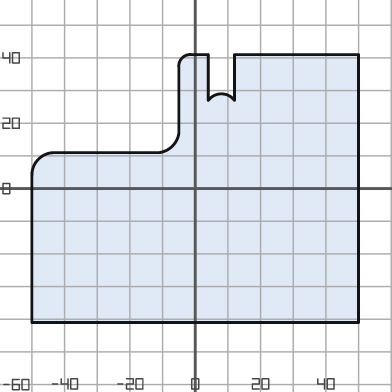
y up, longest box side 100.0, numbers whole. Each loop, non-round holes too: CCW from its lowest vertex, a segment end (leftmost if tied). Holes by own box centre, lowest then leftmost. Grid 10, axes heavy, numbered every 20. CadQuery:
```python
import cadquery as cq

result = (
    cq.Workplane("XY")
    .moveTo(-50.0, -41.0)
    .lineTo(50.0, -41.0)
    .lineTo(50.0, 41.0)
    .lineTo(12.0, 41.0)
    .lineTo(12.0, 27.0)
    .threePointArc((8.0, 29.0), (4.0, 27.0))
    .lineTo(4.0, 41.0)
    .lineTo(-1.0, 41.0)
    .threePointArc((-4.0, 40.0), (-5.0, 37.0))
    .lineTo(-5.0, 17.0)
    .threePointArc((-7.0, 13.0), (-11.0, 11.0))
    .lineTo(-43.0, 11.0)
    .threePointArc((-48.0, 9.0), (-50.0, 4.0))
    .close()
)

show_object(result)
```